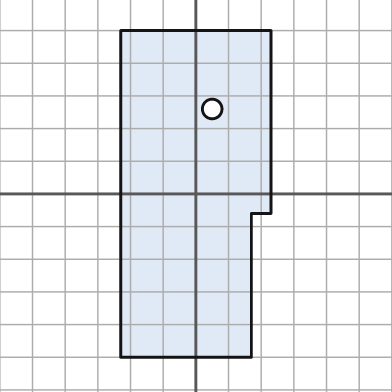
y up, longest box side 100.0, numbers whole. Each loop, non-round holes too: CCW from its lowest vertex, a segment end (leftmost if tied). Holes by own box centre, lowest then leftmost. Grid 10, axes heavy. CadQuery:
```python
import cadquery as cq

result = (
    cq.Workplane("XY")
    .moveTo(-23.0, -50.0)
    .lineTo(17.0, -50.0)
    .lineTo(17.0, -6.0)
    .lineTo(23.0, -6.0)
    .lineTo(23.0, 50.0)
    .lineTo(-23.0, 50.0)
    .close()
    .moveTo(5.0, 26.0)
    .circle(3.0)
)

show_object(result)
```